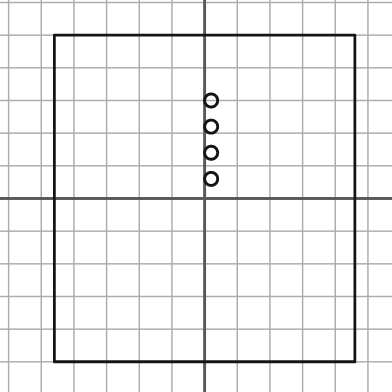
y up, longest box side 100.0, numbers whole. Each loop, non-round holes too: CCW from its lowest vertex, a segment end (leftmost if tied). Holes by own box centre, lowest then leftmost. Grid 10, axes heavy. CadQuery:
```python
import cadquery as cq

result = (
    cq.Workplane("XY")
    .moveTo(-46.0, -50.0)
    .lineTo(46.0, -50.0)
    .lineTo(46.0, 50.0)
    .lineTo(-46.0, 50.0)
    .close()
    .moveTo(2.0, 6.0)
    .circle(2.0)
    .moveTo(2.0, 14.0)
    .circle(2.0)
    .moveTo(2.0, 22.0)
    .circle(2.0)
    .moveTo(2.0, 30.0)
    .circle(2.0)
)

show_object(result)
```